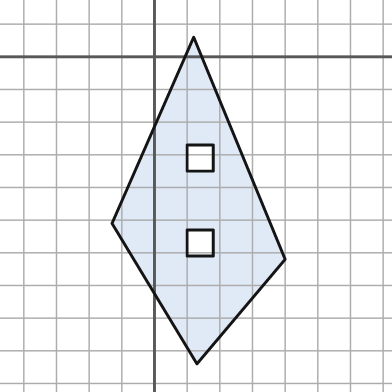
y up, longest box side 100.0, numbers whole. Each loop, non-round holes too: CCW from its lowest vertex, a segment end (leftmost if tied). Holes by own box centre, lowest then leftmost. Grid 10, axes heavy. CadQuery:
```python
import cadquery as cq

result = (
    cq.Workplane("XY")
    .moveTo(13.0, -94.0)
    .lineTo(40.0, -62.0)
    .lineTo(12.0, 6.0)
    .lineTo(-13.0, -51.0)
    .close()
    .moveTo(10.0, -61.0)
    .lineTo(18.0, -61.0)
    .lineTo(18.0, -53.0)
    .lineTo(10.0, -53.0)
    .close()
    .moveTo(10.0, -35.0)
    .lineTo(18.0, -35.0)
    .lineTo(18.0, -27.0)
    .lineTo(10.0, -27.0)
    .close()
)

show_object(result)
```